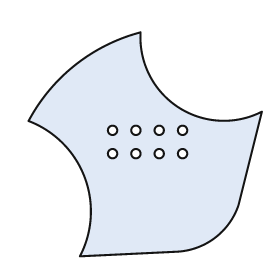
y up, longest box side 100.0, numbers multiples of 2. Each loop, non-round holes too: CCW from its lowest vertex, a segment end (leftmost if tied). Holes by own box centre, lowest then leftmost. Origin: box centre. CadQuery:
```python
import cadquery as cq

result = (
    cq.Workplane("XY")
    .moveTo(-28.0, -48.0)
    .lineTo(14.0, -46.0)
    .threePointArc((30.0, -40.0), (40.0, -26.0))
    .lineTo(50.0, 14.0)
    .threePointArc((14.0, 16.0), (-2.0, 48.0))
    .threePointArc((-30.0, 34.0), (-50.0, 10.0))
    .threePointArc((-26.0, -14.0), (-28.0, -48.0))
    .close()
    .moveTo(-14.0, -4.0)
    .circle(2.0)
    .moveTo(-4.0, -4.0)
    .circle(2.0)
    .moveTo(6.0, -4.0)
    .circle(2.0)
    .moveTo(16.0, -4.0)
    .circle(2.0)
    .moveTo(-14.0, 6.0)
    .circle(2.0)
    .moveTo(-4.0, 6.0)
    .circle(2.0)
    .moveTo(6.0, 6.0)
    .circle(2.0)
    .moveTo(16.0, 6.0)
    .circle(2.0)
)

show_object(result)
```